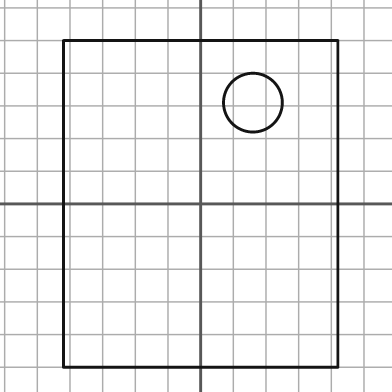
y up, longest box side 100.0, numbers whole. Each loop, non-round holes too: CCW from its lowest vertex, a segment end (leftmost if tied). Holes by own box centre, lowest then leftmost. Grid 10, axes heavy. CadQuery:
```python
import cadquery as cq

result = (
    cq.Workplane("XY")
    .moveTo(-42.0, -50.0)
    .lineTo(42.0, -50.0)
    .lineTo(42.0, 50.0)
    .lineTo(-42.0, 50.0)
    .close()
    .moveTo(16.0, 31.0)
    .circle(9.0)
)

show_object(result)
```